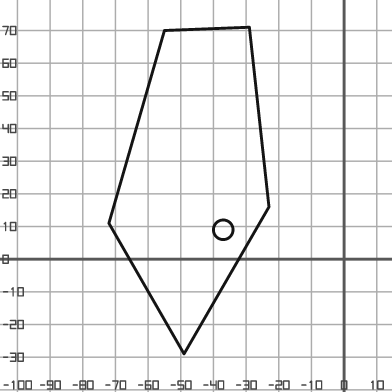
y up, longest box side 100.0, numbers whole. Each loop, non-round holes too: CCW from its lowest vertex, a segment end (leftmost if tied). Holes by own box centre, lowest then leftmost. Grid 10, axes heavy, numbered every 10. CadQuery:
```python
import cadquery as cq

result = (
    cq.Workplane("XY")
    .moveTo(-49.0, -29.0)
    .lineTo(-23.0, 16.0)
    .lineTo(-29.0, 71.0)
    .lineTo(-55.0, 70.0)
    .lineTo(-72.0, 11.0)
    .close()
    .moveTo(-37.0, 9.0)
    .circle(3.0)
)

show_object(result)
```